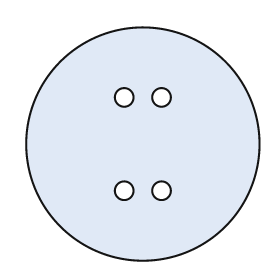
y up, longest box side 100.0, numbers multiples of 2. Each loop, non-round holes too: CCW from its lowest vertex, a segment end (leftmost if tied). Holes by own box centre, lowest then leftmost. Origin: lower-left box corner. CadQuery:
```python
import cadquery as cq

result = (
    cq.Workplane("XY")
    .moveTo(50.0, 50.0)
    .circle(50.0)
    .moveTo(42.0, 30.0)
    .circle(4.0)
    .moveTo(58.0, 30.0)
    .circle(4.0)
    .moveTo(42.0, 70.0)
    .circle(4.0)
    .moveTo(58.0, 70.0)
    .circle(4.0)
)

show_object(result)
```